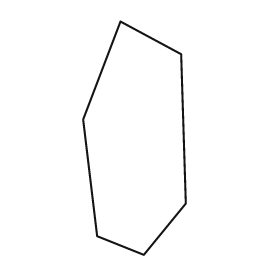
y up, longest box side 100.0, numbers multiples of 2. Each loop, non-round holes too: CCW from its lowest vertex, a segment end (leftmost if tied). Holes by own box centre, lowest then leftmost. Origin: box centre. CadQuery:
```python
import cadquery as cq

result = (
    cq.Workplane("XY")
    .moveTo(4.0, -50.0)
    .lineTo(22.0, -28.0)
    .lineTo(20.0, 36.0)
    .lineTo(-6.0, 50.0)
    .lineTo(-22.0, 8.0)
    .lineTo(-16.0, -42.0)
    .close()
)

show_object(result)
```